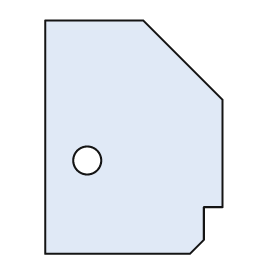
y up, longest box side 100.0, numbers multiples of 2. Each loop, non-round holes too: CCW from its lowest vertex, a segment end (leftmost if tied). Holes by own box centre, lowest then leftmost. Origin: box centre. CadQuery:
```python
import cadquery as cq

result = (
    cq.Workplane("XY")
    .moveTo(-38.0, -50.0)
    .lineTo(24.0, -50.0)
    .lineTo(30.0, -44.0)
    .lineTo(30.0, -30.0)
    .lineTo(38.0, -30.0)
    .lineTo(38.0, 16.0)
    .lineTo(4.0, 50.0)
    .lineTo(-38.0, 50.0)
    .close()
    .moveTo(-20.0, -10.0)
    .circle(6.0)
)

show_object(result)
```